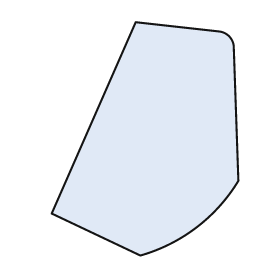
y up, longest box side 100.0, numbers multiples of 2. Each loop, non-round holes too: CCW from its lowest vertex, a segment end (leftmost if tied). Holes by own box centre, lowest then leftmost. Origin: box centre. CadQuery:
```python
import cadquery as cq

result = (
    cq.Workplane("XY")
    .moveTo(-2.0, -50.0)
    .threePointArc((22.0, -38.0), (40.0, -18.0))
    .lineTo(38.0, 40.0)
    .threePointArc((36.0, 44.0), (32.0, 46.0))
    .lineTo(-4.0, 50.0)
    .lineTo(-40.0, -32.0)
    .close()
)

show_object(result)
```